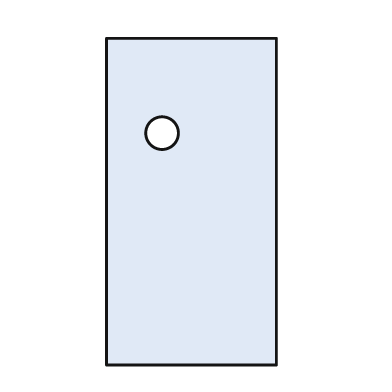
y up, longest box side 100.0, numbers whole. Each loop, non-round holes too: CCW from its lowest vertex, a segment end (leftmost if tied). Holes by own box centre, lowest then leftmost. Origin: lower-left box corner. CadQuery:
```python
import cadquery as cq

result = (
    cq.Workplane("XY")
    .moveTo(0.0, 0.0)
    .lineTo(52.0, 0.0)
    .lineTo(52.0, 100.0)
    .lineTo(0.0, 100.0)
    .close()
    .moveTo(17.0, 71.0)
    .circle(5.0)
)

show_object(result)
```